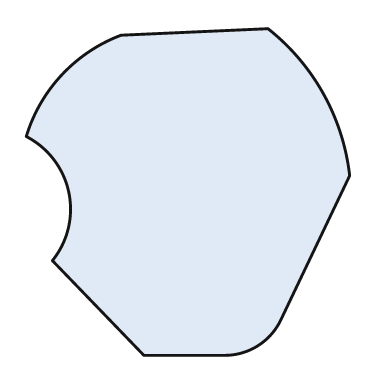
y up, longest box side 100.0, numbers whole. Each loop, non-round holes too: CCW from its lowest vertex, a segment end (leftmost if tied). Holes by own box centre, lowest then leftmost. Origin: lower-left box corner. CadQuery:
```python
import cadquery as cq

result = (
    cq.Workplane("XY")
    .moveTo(36.0, 0.0)
    .lineTo(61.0, 0.0)
    .threePointArc((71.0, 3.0), (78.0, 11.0))
    .lineTo(99.0, 55.0)
    .threePointArc((91.0, 80.0), (74.0, 100.0))
    .lineTo(29.0, 98.0)
    .threePointArc((11.0, 86.0), (0.0, 67.0))
    .threePointArc((13.0, 50.0), (8.0, 29.0))
    .close()
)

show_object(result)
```